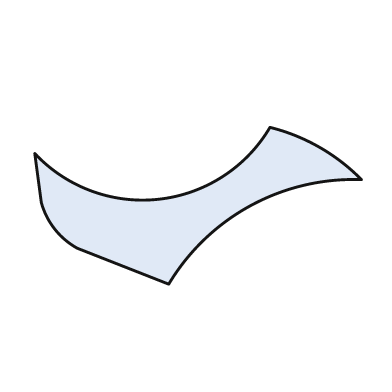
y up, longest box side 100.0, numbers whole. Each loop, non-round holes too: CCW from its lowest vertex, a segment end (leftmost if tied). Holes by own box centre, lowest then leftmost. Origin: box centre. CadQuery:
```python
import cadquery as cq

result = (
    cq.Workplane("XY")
    .moveTo(-9.0, -24.0)
    .threePointArc((16.0, 0.0), (50.0, 8.0))
    .threePointArc((37.0, 18.0), (22.0, 24.0))
    .threePointArc((-12.0, 2.0), (-50.0, 16.0))
    .lineTo(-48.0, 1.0)
    .threePointArc((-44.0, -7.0), (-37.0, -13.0))
    .close()
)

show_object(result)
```